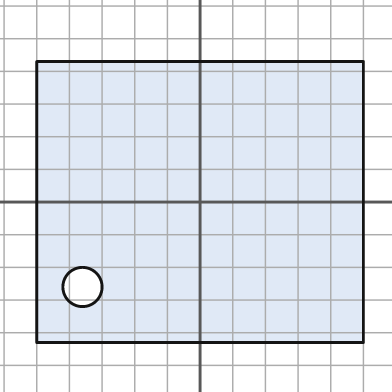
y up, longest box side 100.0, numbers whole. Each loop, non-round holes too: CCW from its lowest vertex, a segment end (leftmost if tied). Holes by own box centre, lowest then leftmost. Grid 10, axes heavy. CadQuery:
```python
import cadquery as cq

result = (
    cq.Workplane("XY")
    .moveTo(-50.0, -43.0)
    .lineTo(50.0, -43.0)
    .lineTo(50.0, 43.0)
    .lineTo(-50.0, 43.0)
    .close()
    .moveTo(-36.0, -26.0)
    .circle(6.0)
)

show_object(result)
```